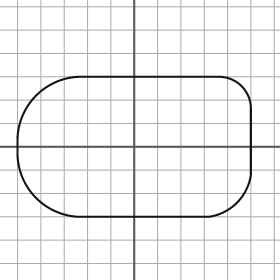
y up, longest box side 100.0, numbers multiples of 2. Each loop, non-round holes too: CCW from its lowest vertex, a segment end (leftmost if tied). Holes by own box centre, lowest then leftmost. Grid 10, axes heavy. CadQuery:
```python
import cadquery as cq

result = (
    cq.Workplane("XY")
    .moveTo(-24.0, -30.0)
    .lineTo(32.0, -30.0)
    .threePointArc((44.0, -24.0), (50.0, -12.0))
    .lineTo(50.0, 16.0)
    .threePointArc((46.0, 26.0), (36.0, 30.0))
    .lineTo(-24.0, 30.0)
    .threePointArc((-42.0, 22.0), (-50.0, 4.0))
    .lineTo(-50.0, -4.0)
    .threePointArc((-42.0, -22.0), (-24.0, -30.0))
    .close()
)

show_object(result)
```